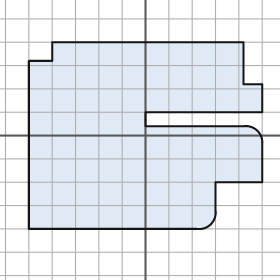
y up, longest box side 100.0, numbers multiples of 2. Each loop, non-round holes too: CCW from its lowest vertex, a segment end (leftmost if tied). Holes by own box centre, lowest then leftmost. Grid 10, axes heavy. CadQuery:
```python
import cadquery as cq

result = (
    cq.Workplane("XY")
    .moveTo(-50.0, -40.0)
    .lineTo(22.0, -40.0)
    .threePointArc((28.0, -38.0), (30.0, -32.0))
    .lineTo(30.0, -20.0)
    .lineTo(50.0, -20.0)
    .lineTo(50.0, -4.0)
    .threePointArc((48.0, 2.0), (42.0, 4.0))
    .lineTo(0.0, 4.0)
    .lineTo(0.0, 10.0)
    .lineTo(50.0, 10.0)
    .lineTo(50.0, 22.0)
    .lineTo(42.0, 22.0)
    .lineTo(42.0, 40.0)
    .lineTo(-40.0, 40.0)
    .lineTo(-40.0, 32.0)
    .lineTo(-50.0, 32.0)
    .close()
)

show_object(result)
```